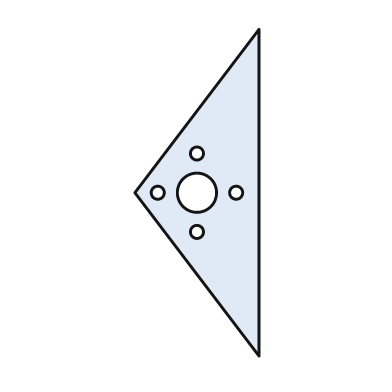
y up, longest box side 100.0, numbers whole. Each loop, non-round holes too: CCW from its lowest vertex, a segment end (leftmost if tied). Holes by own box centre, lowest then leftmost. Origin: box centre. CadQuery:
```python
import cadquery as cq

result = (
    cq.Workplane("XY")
    .moveTo(19.0, -50.0)
    .lineTo(19.0, 50.0)
    .lineTo(-19.0, 0.0)
    .close()
    .moveTo(0.0, -12.0)
    .circle(2.0)
    .moveTo(-12.0, 0.0)
    .circle(2.0)
    .moveTo(0.0, 0.0)
    .circle(6.0)
    .moveTo(12.0, 0.0)
    .circle(2.0)
    .moveTo(0.0, 12.0)
    .circle(2.0)
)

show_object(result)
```